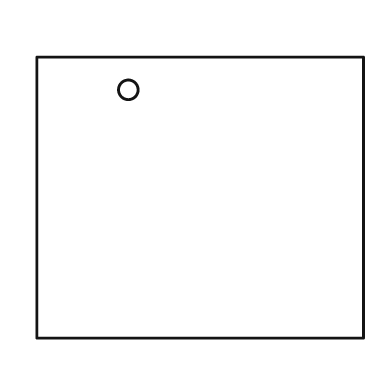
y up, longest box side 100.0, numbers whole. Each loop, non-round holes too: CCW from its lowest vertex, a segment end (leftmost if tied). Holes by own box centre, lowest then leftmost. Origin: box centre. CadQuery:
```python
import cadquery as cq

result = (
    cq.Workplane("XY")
    .moveTo(-50.0, -43.0)
    .lineTo(50.0, -43.0)
    .lineTo(50.0, 43.0)
    .lineTo(-50.0, 43.0)
    .close()
    .moveTo(-22.0, 33.0)
    .circle(3.0)
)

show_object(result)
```